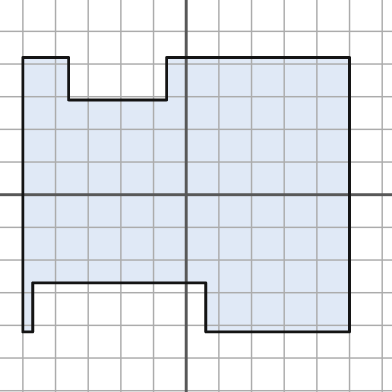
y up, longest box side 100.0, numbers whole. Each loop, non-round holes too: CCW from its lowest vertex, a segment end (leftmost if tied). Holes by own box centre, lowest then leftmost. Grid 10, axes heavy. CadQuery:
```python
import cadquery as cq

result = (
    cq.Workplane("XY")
    .moveTo(-50.0, -42.0)
    .lineTo(-47.0, -42.0)
    .lineTo(-47.0, -27.0)
    .lineTo(6.0, -27.0)
    .lineTo(6.0, -42.0)
    .lineTo(50.0, -42.0)
    .lineTo(50.0, 42.0)
    .lineTo(-6.0, 42.0)
    .lineTo(-6.0, 29.0)
    .lineTo(-36.0, 29.0)
    .lineTo(-36.0, 42.0)
    .lineTo(-50.0, 42.0)
    .close()
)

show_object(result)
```